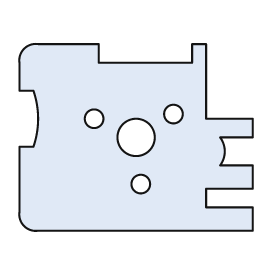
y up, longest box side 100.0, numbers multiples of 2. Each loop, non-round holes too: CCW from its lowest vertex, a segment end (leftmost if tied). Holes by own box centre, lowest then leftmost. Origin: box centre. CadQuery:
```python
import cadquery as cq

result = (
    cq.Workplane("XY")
    .moveTo(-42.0, -40.0)
    .lineTo(50.0, -40.0)
    .lineTo(50.0, -30.0)
    .lineTo(30.0, -30.0)
    .lineTo(30.0, -22.0)
    .lineTo(50.0, -22.0)
    .lineTo(50.0, -12.0)
    .lineTo(36.0, -12.0)
    .threePointArc((38.0, -6.0), (36.0, 0.0))
    .lineTo(50.0, 0.0)
    .lineTo(50.0, 8.0)
    .lineTo(30.0, 8.0)
    .lineTo(30.0, 40.0)
    .lineTo(24.0, 40.0)
    .lineTo(24.0, 32.0)
    .lineTo(-16.0, 32.0)
    .lineTo(-16.0, 40.0)
    .lineTo(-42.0, 40.0)
    .threePointArc((-48.0, 38.0), (-50.0, 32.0))
    .lineTo(-50.0, 20.0)
    .lineTo(-44.0, 20.0)
    .threePointArc((-42.0, 8.0), (-44.0, -4.0))
    .lineTo(-50.0, -4.0)
    .lineTo(-50.0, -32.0)
    .threePointArc((-48.0, -38.0), (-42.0, -40.0))
    .close()
    .moveTo(2.0, -20.0)
    .circle(4.0)
    .moveTo(0.0, 0.0)
    .circle(8.0)
    .moveTo(-18.0, 8.0)
    .circle(4.0)
    .moveTo(16.0, 10.0)
    .circle(4.0)
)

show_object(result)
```